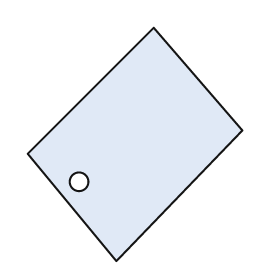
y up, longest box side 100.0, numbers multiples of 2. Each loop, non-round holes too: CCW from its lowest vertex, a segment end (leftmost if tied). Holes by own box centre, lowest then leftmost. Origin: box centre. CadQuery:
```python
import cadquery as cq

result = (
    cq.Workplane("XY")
    .moveTo(-8.0, -50.0)
    .lineTo(46.0, 6.0)
    .lineTo(8.0, 50.0)
    .lineTo(-46.0, -4.0)
    .close()
    .moveTo(-24.0, -16.0)
    .circle(4.0)
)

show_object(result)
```